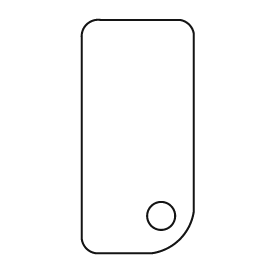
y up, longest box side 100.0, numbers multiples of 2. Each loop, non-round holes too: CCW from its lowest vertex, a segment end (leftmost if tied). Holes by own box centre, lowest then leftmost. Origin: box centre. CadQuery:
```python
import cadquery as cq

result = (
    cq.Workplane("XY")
    .moveTo(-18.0, -50.0)
    .lineTo(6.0, -50.0)
    .threePointArc((18.0, -44.0), (24.0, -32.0))
    .lineTo(24.0, 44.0)
    .threePointArc((22.0, 48.0), (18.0, 50.0))
    .lineTo(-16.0, 50.0)
    .threePointArc((-22.0, 48.0), (-24.0, 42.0))
    .lineTo(-24.0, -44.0)
    .threePointArc((-22.0, -48.0), (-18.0, -50.0))
    .close()
    .moveTo(10.0, -34.0)
    .circle(6.0)
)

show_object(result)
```